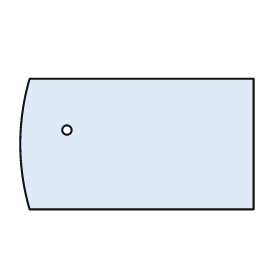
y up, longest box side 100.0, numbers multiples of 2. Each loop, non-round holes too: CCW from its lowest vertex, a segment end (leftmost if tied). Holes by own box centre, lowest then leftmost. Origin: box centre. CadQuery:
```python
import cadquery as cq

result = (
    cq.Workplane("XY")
    .moveTo(-46.0, -28.0)
    .lineTo(50.0, -28.0)
    .lineTo(50.0, 28.0)
    .lineTo(-46.0, 28.0)
    .threePointArc((-50.0, 0.0), (-46.0, -28.0))
    .close()
    .moveTo(-30.0, 6.0)
    .circle(2.0)
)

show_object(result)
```